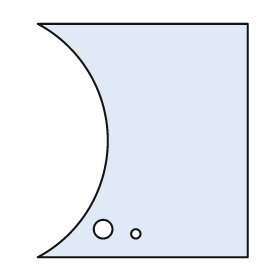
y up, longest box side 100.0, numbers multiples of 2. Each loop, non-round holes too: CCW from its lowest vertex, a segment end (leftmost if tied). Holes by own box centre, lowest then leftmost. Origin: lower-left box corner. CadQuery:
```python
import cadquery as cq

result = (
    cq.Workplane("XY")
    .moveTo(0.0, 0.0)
    .lineTo(90.0, 0.0)
    .lineTo(90.0, 100.0)
    .lineTo(0.0, 100.0)
    .threePointArc((30.0, 50.0), (0.0, 0.0))
    .close()
    .moveTo(42.0, 10.0)
    .circle(2.0)
    .moveTo(28.0, 12.0)
    .circle(4.0)
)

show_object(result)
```